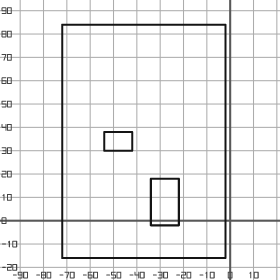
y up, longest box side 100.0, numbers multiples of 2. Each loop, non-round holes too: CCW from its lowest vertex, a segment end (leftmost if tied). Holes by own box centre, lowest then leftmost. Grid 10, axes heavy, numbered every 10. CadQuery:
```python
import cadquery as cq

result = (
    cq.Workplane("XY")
    .moveTo(-72.0, -16.0)
    .lineTo(-2.0, -16.0)
    .lineTo(-2.0, 84.0)
    .lineTo(-72.0, 84.0)
    .close()
    .moveTo(-34.0, -2.0)
    .lineTo(-22.0, -2.0)
    .lineTo(-22.0, 18.0)
    .lineTo(-34.0, 18.0)
    .close()
    .moveTo(-54.0, 30.0)
    .lineTo(-42.0, 30.0)
    .lineTo(-42.0, 38.0)
    .lineTo(-54.0, 38.0)
    .close()
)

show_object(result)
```